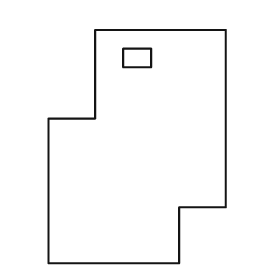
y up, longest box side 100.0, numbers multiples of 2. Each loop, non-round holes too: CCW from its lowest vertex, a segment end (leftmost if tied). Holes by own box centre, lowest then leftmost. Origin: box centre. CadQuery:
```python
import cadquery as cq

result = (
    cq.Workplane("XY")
    .moveTo(-38.0, -50.0)
    .lineTo(18.0, -50.0)
    .lineTo(18.0, -26.0)
    .lineTo(38.0, -26.0)
    .lineTo(38.0, 50.0)
    .lineTo(-18.0, 50.0)
    .lineTo(-18.0, 12.0)
    .lineTo(-38.0, 12.0)
    .close()
    .moveTo(-6.0, 34.0)
    .lineTo(6.0, 34.0)
    .lineTo(6.0, 42.0)
    .lineTo(-6.0, 42.0)
    .close()
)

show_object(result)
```